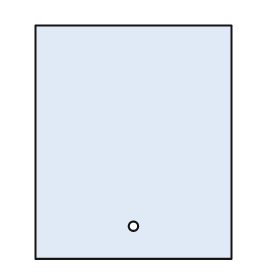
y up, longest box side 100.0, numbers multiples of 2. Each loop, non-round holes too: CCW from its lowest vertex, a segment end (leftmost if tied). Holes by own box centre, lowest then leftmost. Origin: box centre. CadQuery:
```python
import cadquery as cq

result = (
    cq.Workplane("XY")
    .moveTo(-42.0, -50.0)
    .lineTo(42.0, -50.0)
    .lineTo(42.0, 50.0)
    .lineTo(-42.0, 50.0)
    .close()
    .moveTo(0.0, -36.0)
    .circle(2.0)
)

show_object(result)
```